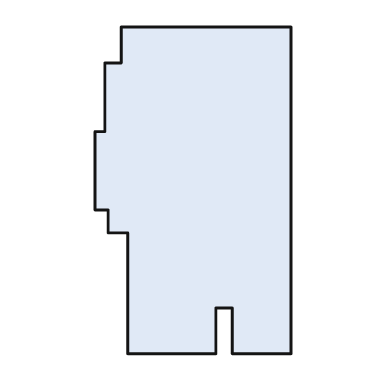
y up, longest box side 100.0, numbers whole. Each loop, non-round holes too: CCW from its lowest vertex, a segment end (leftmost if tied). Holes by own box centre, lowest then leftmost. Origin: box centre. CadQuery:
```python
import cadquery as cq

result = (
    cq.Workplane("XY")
    .moveTo(-20.0, -50.0)
    .lineTo(7.0, -50.0)
    .lineTo(7.0, -36.0)
    .lineTo(12.0, -36.0)
    .lineTo(12.0, -50.0)
    .lineTo(30.0, -50.0)
    .lineTo(30.0, 50.0)
    .lineTo(-22.0, 50.0)
    .lineTo(-22.0, 39.0)
    .lineTo(-27.0, 39.0)
    .lineTo(-27.0, 18.0)
    .lineTo(-30.0, 18.0)
    .lineTo(-30.0, -6.0)
    .lineTo(-26.0, -6.0)
    .lineTo(-26.0, -13.0)
    .lineTo(-20.0, -13.0)
    .close()
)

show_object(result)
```